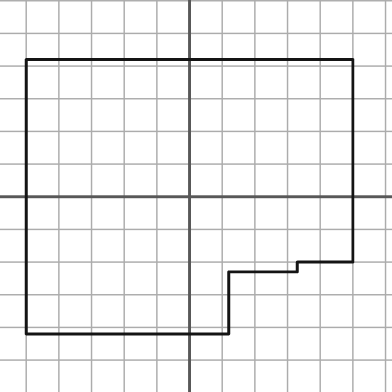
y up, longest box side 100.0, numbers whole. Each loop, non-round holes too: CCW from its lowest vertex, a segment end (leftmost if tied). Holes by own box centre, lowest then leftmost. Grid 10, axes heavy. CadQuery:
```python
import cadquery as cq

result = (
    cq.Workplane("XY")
    .moveTo(-50.0, -42.0)
    .lineTo(12.0, -42.0)
    .lineTo(12.0, -23.0)
    .lineTo(33.0, -23.0)
    .lineTo(33.0, -20.0)
    .lineTo(50.0, -20.0)
    .lineTo(50.0, 42.0)
    .lineTo(-50.0, 42.0)
    .close()
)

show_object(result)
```